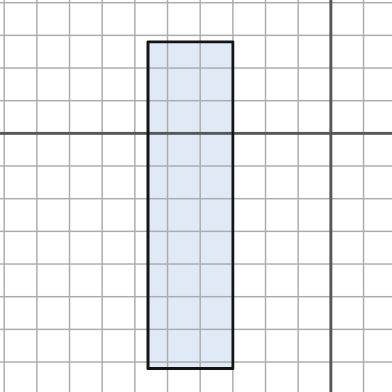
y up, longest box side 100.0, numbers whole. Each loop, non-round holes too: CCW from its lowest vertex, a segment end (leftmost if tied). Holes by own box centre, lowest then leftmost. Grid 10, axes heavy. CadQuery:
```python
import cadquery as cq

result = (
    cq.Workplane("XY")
    .moveTo(-56.0, -72.0)
    .lineTo(-30.0, -72.0)
    .lineTo(-30.0, 28.0)
    .lineTo(-56.0, 28.0)
    .close()
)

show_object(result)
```